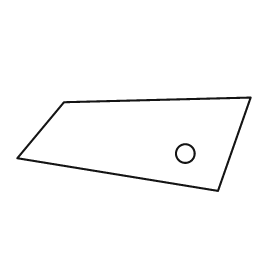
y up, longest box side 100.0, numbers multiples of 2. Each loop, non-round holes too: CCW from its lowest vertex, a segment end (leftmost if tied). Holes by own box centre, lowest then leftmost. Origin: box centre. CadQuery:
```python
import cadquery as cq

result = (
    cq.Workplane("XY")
    .moveTo(36.0, -20.0)
    .lineTo(50.0, 20.0)
    .lineTo(-30.0, 18.0)
    .lineTo(-50.0, -6.0)
    .close()
    .moveTo(22.0, -4.0)
    .circle(4.0)
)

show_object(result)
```